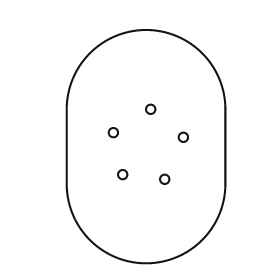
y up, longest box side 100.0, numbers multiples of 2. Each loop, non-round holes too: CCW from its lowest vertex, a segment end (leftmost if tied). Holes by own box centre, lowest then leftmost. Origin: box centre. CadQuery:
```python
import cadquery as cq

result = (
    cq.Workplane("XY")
    .moveTo(-34.0, -16.0)
    .threePointArc((0.0, -50.0), (34.0, -16.0))
    .lineTo(34.0, 16.0)
    .threePointArc((0.0, 50.0), (-34.0, 16.0))
    .close()
    .moveTo(8.0, -14.0)
    .circle(2.0)
    .moveTo(-10.0, -12.0)
    .circle(2.0)
    .moveTo(16.0, 4.0)
    .circle(2.0)
    .moveTo(-14.0, 6.0)
    .circle(2.0)
    .moveTo(2.0, 16.0)
    .circle(2.0)
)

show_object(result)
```